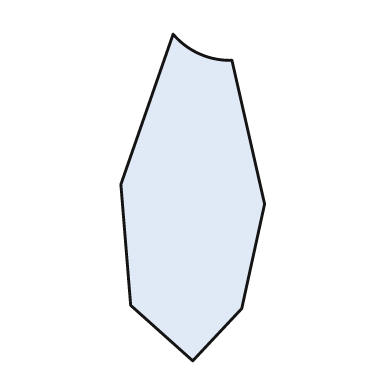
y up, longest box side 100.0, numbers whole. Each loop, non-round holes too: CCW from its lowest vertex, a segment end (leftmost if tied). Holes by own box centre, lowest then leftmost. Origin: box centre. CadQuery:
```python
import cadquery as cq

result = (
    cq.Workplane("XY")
    .moveTo(0.0, -50.0)
    .lineTo(15.0, -34.0)
    .lineTo(22.0, -2.0)
    .lineTo(12.0, 42.0)
    .threePointArc((2.0, 44.0), (-6.0, 50.0))
    .lineTo(-22.0, 4.0)
    .lineTo(-19.0, -33.0)
    .close()
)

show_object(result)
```